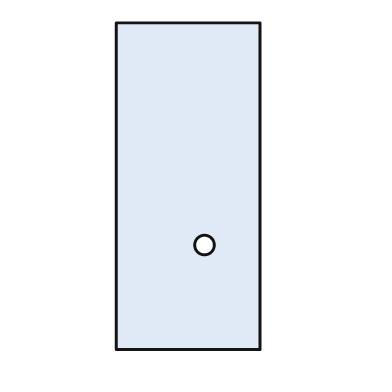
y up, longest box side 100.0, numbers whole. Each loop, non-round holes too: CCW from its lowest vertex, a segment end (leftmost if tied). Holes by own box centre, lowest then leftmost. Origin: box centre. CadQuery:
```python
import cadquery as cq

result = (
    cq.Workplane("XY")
    .moveTo(-22.0, -50.0)
    .lineTo(22.0, -50.0)
    .lineTo(22.0, 50.0)
    .lineTo(-22.0, 50.0)
    .close()
    .moveTo(5.0, -18.0)
    .circle(3.0)
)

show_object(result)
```